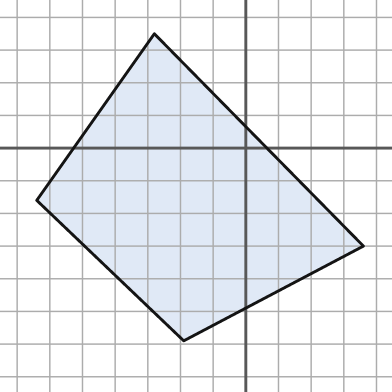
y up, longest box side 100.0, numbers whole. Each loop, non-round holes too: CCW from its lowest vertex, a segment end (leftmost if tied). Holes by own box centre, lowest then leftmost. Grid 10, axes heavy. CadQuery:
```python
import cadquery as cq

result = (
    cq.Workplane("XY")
    .moveTo(-19.0, -59.0)
    .lineTo(36.0, -30.0)
    .lineTo(-28.0, 35.0)
    .lineTo(-64.0, -16.0)
    .close()
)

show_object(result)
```